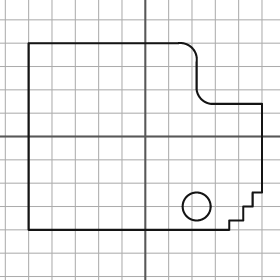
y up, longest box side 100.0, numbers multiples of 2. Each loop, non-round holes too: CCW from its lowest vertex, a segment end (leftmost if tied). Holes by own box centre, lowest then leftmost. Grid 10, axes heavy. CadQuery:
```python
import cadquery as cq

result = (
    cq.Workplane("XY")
    .moveTo(-50.0, -40.0)
    .lineTo(36.0, -40.0)
    .lineTo(36.0, -36.0)
    .lineTo(42.0, -36.0)
    .lineTo(42.0, -30.0)
    .lineTo(46.0, -30.0)
    .lineTo(46.0, -24.0)
    .lineTo(50.0, -24.0)
    .lineTo(50.0, 14.0)
    .lineTo(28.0, 14.0)
    .threePointArc((24.0, 16.0), (22.0, 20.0))
    .lineTo(22.0, 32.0)
    .threePointArc((20.0, 38.0), (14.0, 40.0))
    .lineTo(-50.0, 40.0)
    .close()
    .moveTo(22.0, -30.0)
    .circle(6.0)
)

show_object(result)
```